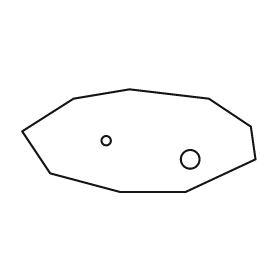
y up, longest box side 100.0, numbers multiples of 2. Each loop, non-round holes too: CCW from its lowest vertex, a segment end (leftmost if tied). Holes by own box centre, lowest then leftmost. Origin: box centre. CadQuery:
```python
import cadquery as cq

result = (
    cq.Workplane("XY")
    .moveTo(-8.0, -22.0)
    .lineTo(20.0, -22.0)
    .lineTo(50.0, -8.0)
    .lineTo(48.0, 6.0)
    .lineTo(30.0, 18.0)
    .lineTo(-4.0, 22.0)
    .lineTo(-28.0, 18.0)
    .lineTo(-50.0, 4.0)
    .lineTo(-38.0, -14.0)
    .close()
    .moveTo(22.0, -8.0)
    .circle(4.0)
    .moveTo(-14.0, 0.0)
    .circle(2.0)
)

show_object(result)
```